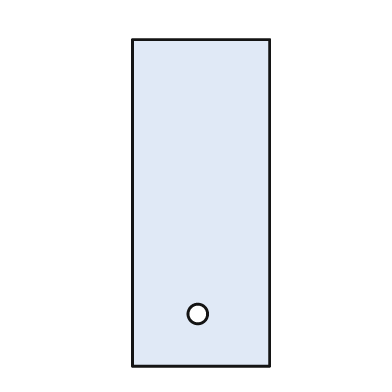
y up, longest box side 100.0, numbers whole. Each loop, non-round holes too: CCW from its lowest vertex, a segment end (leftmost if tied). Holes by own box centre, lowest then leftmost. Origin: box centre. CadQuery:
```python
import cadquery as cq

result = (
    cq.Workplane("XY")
    .moveTo(-21.0, -50.0)
    .lineTo(21.0, -50.0)
    .lineTo(21.0, 50.0)
    .lineTo(-21.0, 50.0)
    .close()
    .moveTo(-1.0, -34.0)
    .circle(3.0)
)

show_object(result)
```